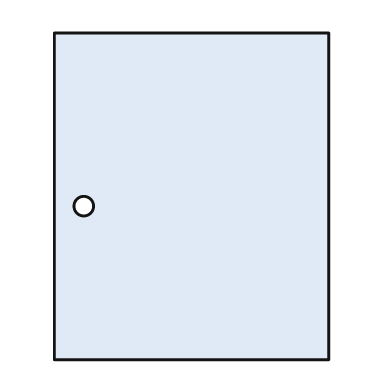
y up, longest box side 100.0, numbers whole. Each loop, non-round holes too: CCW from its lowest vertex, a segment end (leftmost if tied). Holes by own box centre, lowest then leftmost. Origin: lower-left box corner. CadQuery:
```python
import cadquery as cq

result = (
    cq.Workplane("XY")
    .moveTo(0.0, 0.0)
    .lineTo(84.0, 0.0)
    .lineTo(84.0, 100.0)
    .lineTo(0.0, 100.0)
    .close()
    .moveTo(9.0, 47.0)
    .circle(3.0)
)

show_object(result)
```